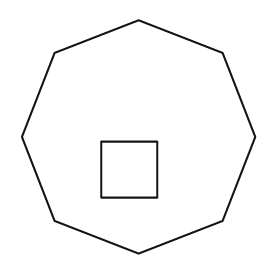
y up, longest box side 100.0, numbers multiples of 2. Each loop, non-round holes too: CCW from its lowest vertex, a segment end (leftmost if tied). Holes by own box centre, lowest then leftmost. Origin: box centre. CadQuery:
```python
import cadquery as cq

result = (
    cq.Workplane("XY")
    .moveTo(0.0, -50.0)
    .lineTo(36.0, -36.0)
    .lineTo(50.0, 0.0)
    .lineTo(36.0, 36.0)
    .lineTo(0.0, 50.0)
    .lineTo(-36.0, 36.0)
    .lineTo(-50.0, 0.0)
    .lineTo(-36.0, -36.0)
    .close()
    .moveTo(-16.0, -26.0)
    .lineTo(8.0, -26.0)
    .lineTo(8.0, -2.0)
    .lineTo(-16.0, -2.0)
    .close()
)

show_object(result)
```